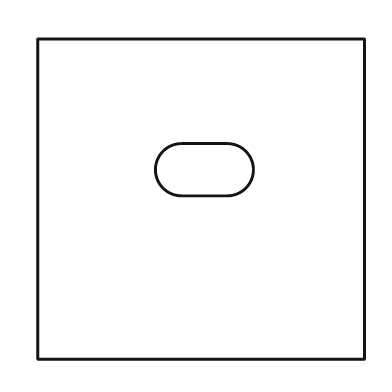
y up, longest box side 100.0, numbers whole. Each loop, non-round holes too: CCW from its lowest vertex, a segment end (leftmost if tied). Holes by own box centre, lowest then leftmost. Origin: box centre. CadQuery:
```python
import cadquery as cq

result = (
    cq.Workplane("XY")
    .moveTo(-50.0, -49.0)
    .lineTo(50.0, -49.0)
    .lineTo(50.0, 49.0)
    .lineTo(-50.0, 49.0)
    .close()
    .moveTo(-6.0, 1.0)
    .lineTo(8.0, 1.0)
    .threePointArc((16.0, 9.0), (8.0, 17.0))
    .lineTo(-6.0, 17.0)
    .threePointArc((-14.0, 9.0), (-6.0, 1.0))
    .close()
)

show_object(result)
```